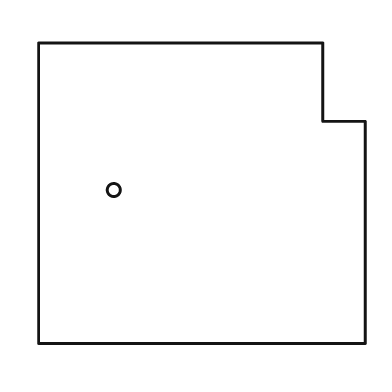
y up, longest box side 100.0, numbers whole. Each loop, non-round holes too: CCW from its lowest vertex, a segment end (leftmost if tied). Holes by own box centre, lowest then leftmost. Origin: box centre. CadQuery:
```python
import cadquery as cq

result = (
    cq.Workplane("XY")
    .moveTo(-50.0, -46.0)
    .lineTo(50.0, -46.0)
    .lineTo(50.0, 22.0)
    .lineTo(37.0, 22.0)
    .lineTo(37.0, 46.0)
    .lineTo(-50.0, 46.0)
    .close()
    .moveTo(-27.0, 1.0)
    .circle(2.0)
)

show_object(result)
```